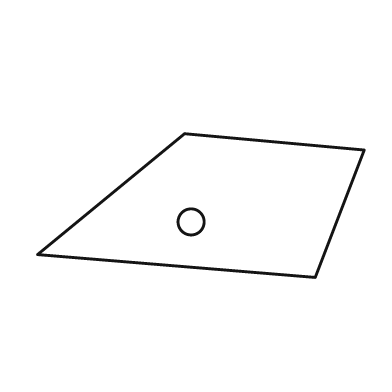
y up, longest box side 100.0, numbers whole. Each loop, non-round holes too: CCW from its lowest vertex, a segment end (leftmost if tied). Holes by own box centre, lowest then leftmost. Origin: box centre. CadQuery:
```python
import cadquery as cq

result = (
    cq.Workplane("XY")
    .moveTo(35.0, -22.0)
    .lineTo(50.0, 17.0)
    .lineTo(-5.0, 22.0)
    .lineTo(-50.0, -15.0)
    .close()
    .moveTo(-3.0, -5.0)
    .circle(4.0)
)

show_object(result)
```